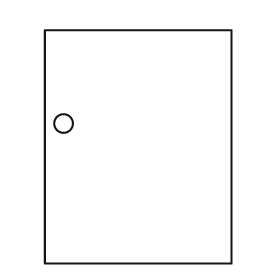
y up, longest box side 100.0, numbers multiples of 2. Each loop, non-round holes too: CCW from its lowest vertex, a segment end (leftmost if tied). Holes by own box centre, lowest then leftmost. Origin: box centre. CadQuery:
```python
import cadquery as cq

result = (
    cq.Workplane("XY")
    .moveTo(-40.0, -50.0)
    .lineTo(40.0, -50.0)
    .lineTo(40.0, 50.0)
    .lineTo(-40.0, 50.0)
    .close()
    .moveTo(-32.0, 10.0)
    .circle(4.0)
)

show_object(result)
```